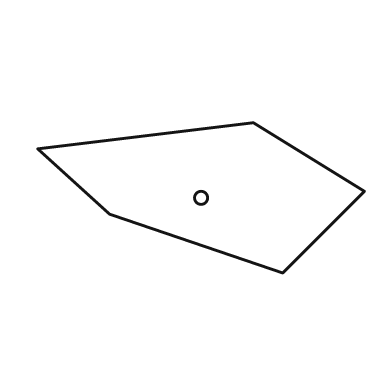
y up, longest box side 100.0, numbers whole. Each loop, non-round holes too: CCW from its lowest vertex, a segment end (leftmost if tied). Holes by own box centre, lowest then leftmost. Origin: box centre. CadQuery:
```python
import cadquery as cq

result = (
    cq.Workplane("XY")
    .moveTo(25.0, -23.0)
    .lineTo(50.0, 2.0)
    .lineTo(16.0, 23.0)
    .lineTo(-50.0, 15.0)
    .lineTo(-28.0, -5.0)
    .close()
    .moveTo(0.0, 0.0)
    .circle(2.0)
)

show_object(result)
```